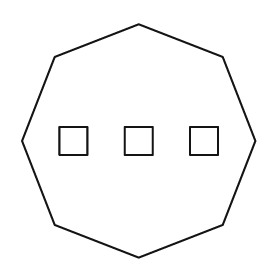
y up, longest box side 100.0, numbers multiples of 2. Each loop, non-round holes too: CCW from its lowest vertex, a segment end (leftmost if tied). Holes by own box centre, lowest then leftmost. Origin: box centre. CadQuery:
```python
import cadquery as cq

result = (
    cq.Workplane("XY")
    .moveTo(0.0, -50.0)
    .lineTo(36.0, -36.0)
    .lineTo(50.0, 0.0)
    .lineTo(36.0, 36.0)
    .lineTo(0.0, 50.0)
    .lineTo(-36.0, 36.0)
    .lineTo(-50.0, 0.0)
    .lineTo(-36.0, -36.0)
    .close()
    .moveTo(-34.0, -6.0)
    .lineTo(-22.0, -6.0)
    .lineTo(-22.0, 6.0)
    .lineTo(-34.0, 6.0)
    .close()
    .moveTo(-6.0, -6.0)
    .lineTo(6.0, -6.0)
    .lineTo(6.0, 6.0)
    .lineTo(-6.0, 6.0)
    .close()
    .moveTo(22.0, -6.0)
    .lineTo(34.0, -6.0)
    .lineTo(34.0, 6.0)
    .lineTo(22.0, 6.0)
    .close()
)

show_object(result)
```